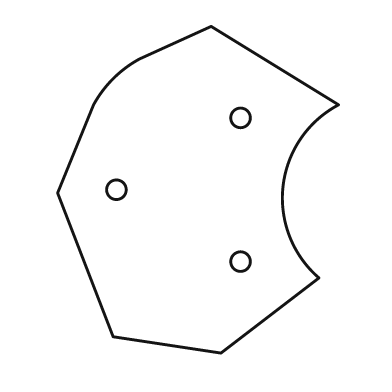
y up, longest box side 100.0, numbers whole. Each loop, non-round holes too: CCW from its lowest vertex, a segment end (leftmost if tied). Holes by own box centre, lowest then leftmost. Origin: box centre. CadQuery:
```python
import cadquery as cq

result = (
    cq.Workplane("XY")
    .moveTo(7.0, -50.0)
    .lineTo(37.0, -27.0)
    .threePointArc((26.0, 1.0), (43.0, 26.0))
    .lineTo(4.0, 50.0)
    .lineTo(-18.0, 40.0)
    .threePointArc((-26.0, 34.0), (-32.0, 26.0))
    .lineTo(-43.0, -1.0)
    .lineTo(-26.0, -45.0)
    .close()
    .moveTo(13.0, -22.0)
    .circle(3.0)
    .moveTo(-25.0, 0.0)
    .circle(3.0)
    .moveTo(13.0, 22.0)
    .circle(3.0)
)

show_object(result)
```